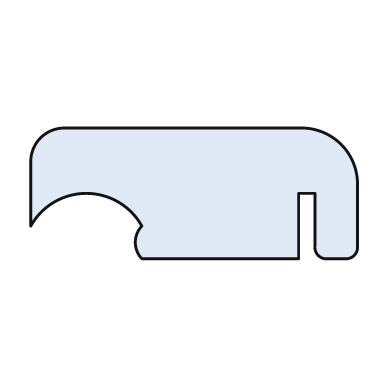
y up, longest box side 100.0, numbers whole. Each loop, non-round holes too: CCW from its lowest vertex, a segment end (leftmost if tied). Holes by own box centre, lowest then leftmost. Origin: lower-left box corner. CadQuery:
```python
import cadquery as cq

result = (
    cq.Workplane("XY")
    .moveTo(34.0, 0.0)
    .lineTo(82.0, 0.0)
    .lineTo(82.0, 20.0)
    .lineTo(87.0, 20.0)
    .lineTo(87.0, 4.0)
    .threePointArc((88.0, 1.0), (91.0, 0.0))
    .lineTo(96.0, 0.0)
    .threePointArc((99.0, 1.0), (100.0, 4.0))
    .lineTo(100.0, 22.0)
    .threePointArc((95.0, 35.0), (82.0, 40.0))
    .lineTo(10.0, 40.0)
    .threePointArc((3.0, 37.0), (0.0, 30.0))
    .lineTo(0.0, 10.0)
    .threePointArc((17.0, 20.0), (34.0, 10.0))
    .threePointArc((32.0, 5.0), (34.0, 0.0))
    .close()
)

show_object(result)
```